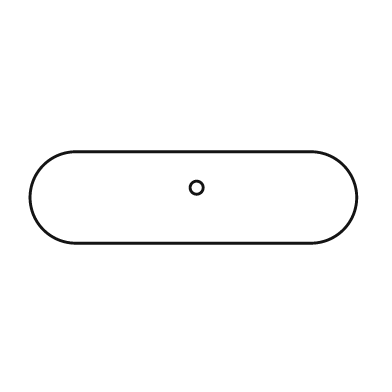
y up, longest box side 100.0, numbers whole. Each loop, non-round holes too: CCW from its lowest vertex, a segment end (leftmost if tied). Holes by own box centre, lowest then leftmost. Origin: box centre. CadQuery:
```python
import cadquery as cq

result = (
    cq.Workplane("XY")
    .moveTo(-36.0, -14.0)
    .lineTo(36.0, -14.0)
    .threePointArc((50.0, 0.0), (36.0, 14.0))
    .lineTo(-36.0, 14.0)
    .threePointArc((-50.0, 0.0), (-36.0, -14.0))
    .close()
    .moveTo(1.0, 3.0)
    .circle(2.0)
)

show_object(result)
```